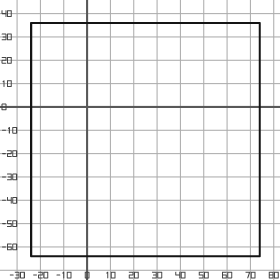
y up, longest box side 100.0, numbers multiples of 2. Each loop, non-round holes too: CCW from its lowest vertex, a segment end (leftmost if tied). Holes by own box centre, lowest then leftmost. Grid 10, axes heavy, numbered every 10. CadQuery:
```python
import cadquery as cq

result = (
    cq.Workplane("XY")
    .moveTo(-24.0, -64.0)
    .lineTo(74.0, -64.0)
    .lineTo(74.0, 36.0)
    .lineTo(-24.0, 36.0)
    .close()
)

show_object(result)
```